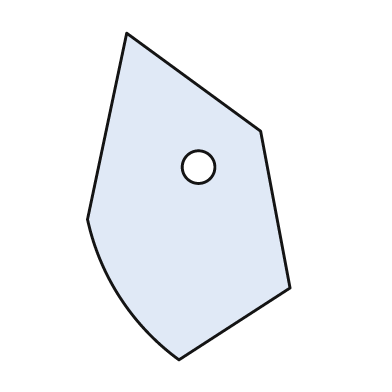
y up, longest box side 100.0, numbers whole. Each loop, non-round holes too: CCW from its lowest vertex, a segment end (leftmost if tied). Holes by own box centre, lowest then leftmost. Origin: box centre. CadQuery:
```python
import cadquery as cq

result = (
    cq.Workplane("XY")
    .moveTo(-3.0, -50.0)
    .lineTo(31.0, -28.0)
    .lineTo(22.0, 20.0)
    .lineTo(-19.0, 50.0)
    .lineTo(-31.0, -7.0)
    .threePointArc((-21.0, -31.0), (-3.0, -50.0))
    .close()
    .moveTo(3.0, 9.0)
    .circle(5.0)
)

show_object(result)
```